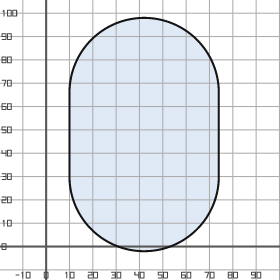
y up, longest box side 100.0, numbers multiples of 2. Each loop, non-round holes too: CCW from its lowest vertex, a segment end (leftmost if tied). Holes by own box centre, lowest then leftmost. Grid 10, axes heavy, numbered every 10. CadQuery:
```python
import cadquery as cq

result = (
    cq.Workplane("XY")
    .moveTo(10.0, 30.0)
    .threePointArc((42.0, -2.0), (74.0, 30.0))
    .lineTo(74.0, 66.0)
    .threePointArc((42.0, 98.0), (10.0, 66.0))
    .close()
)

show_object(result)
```